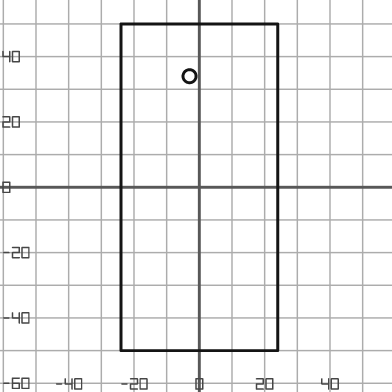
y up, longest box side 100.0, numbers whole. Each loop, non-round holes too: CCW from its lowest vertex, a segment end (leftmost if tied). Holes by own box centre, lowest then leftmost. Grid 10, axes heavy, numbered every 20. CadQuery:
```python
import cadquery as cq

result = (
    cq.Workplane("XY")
    .moveTo(-24.0, -50.0)
    .lineTo(24.0, -50.0)
    .lineTo(24.0, 50.0)
    .lineTo(-24.0, 50.0)
    .close()
    .moveTo(-3.0, 34.0)
    .circle(2.0)
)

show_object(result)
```